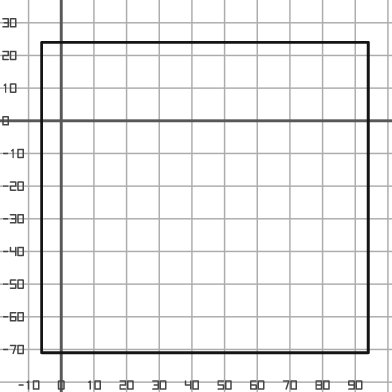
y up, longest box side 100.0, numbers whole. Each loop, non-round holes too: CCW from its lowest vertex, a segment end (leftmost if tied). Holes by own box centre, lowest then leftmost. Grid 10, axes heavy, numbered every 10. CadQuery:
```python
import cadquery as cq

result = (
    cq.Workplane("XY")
    .moveTo(-6.0, -71.0)
    .lineTo(94.0, -71.0)
    .lineTo(94.0, 24.0)
    .lineTo(-6.0, 24.0)
    .close()
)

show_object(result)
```